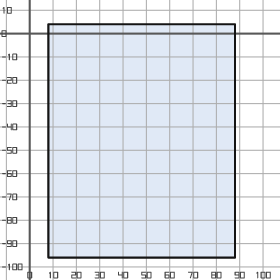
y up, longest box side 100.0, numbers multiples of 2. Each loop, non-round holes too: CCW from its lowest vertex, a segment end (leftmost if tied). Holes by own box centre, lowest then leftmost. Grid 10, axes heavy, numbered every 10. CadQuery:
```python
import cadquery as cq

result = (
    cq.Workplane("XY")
    .moveTo(8.0, -96.0)
    .lineTo(88.0, -96.0)
    .lineTo(88.0, 4.0)
    .lineTo(8.0, 4.0)
    .close()
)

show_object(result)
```